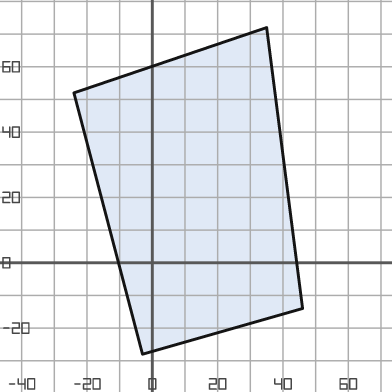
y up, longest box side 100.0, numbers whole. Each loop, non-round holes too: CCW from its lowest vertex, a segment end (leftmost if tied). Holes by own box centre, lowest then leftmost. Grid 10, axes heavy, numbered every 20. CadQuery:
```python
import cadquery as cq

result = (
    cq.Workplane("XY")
    .moveTo(-3.0, -28.0)
    .lineTo(46.0, -14.0)
    .lineTo(35.0, 72.0)
    .lineTo(-24.0, 52.0)
    .close()
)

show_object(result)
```